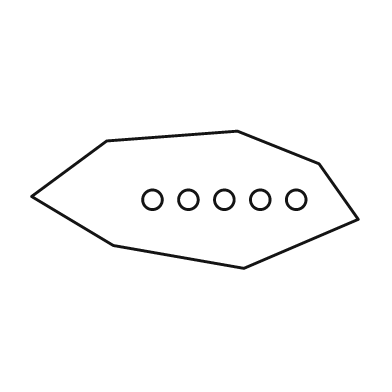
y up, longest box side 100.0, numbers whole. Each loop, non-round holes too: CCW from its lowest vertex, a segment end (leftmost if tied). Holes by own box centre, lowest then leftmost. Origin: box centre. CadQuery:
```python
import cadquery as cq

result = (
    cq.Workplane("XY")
    .moveTo(15.0, -21.0)
    .lineTo(50.0, -6.0)
    .lineTo(38.0, 11.0)
    .lineTo(13.0, 21.0)
    .lineTo(-27.0, 18.0)
    .lineTo(-50.0, 1.0)
    .lineTo(-25.0, -14.0)
    .close()
    .moveTo(-13.0, 0.0)
    .circle(3.0)
    .moveTo(-2.0, 0.0)
    .circle(3.0)
    .moveTo(9.0, 0.0)
    .circle(3.0)
    .moveTo(20.0, 0.0)
    .circle(3.0)
    .moveTo(31.0, 0.0)
    .circle(3.0)
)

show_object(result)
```